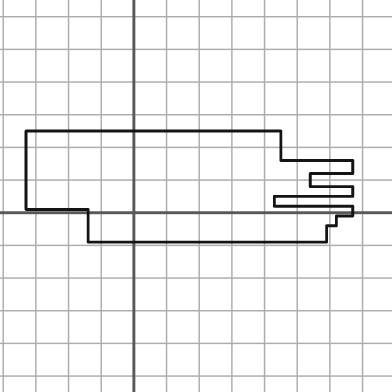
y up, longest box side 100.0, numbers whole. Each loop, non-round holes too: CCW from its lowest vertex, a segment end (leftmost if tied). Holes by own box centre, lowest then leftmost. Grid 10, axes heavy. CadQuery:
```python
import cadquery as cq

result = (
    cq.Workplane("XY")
    .moveTo(-14.0, -9.0)
    .lineTo(59.0, -9.0)
    .lineTo(59.0, -4.0)
    .lineTo(62.0, -4.0)
    .lineTo(62.0, -1.0)
    .lineTo(67.0, -1.0)
    .lineTo(67.0, 2.0)
    .lineTo(43.0, 2.0)
    .lineTo(43.0, 5.0)
    .lineTo(67.0, 5.0)
    .lineTo(67.0, 8.0)
    .lineTo(54.0, 8.0)
    .lineTo(54.0, 12.0)
    .lineTo(67.0, 12.0)
    .lineTo(67.0, 16.0)
    .lineTo(45.0, 16.0)
    .lineTo(45.0, 25.0)
    .lineTo(-33.0, 25.0)
    .lineTo(-33.0, 1.0)
    .lineTo(-14.0, 1.0)
    .close()
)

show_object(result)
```